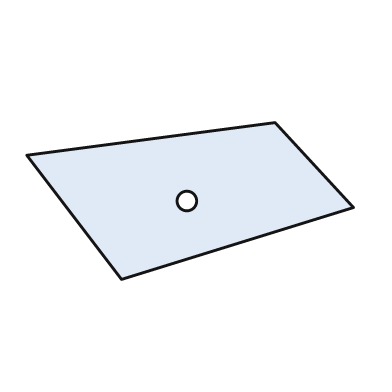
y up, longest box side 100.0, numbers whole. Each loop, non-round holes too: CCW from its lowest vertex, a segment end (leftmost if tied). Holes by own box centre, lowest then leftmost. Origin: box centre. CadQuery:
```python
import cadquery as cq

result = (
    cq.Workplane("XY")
    .moveTo(-21.0, -24.0)
    .lineTo(50.0, -2.0)
    .lineTo(26.0, 24.0)
    .lineTo(-50.0, 14.0)
    .close()
    .moveTo(-1.0, 0.0)
    .circle(3.0)
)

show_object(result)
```